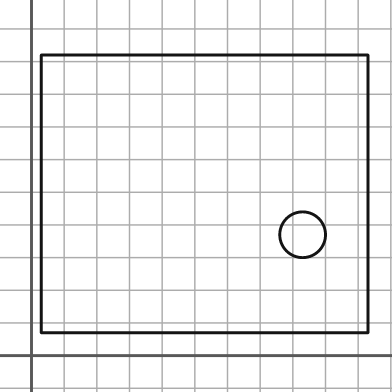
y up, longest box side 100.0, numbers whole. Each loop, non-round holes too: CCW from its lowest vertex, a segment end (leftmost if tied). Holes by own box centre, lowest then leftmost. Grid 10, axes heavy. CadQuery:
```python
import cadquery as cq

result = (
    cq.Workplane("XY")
    .moveTo(3.0, 7.0)
    .lineTo(103.0, 7.0)
    .lineTo(103.0, 92.0)
    .lineTo(3.0, 92.0)
    .close()
    .moveTo(83.0, 37.0)
    .circle(7.0)
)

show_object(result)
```